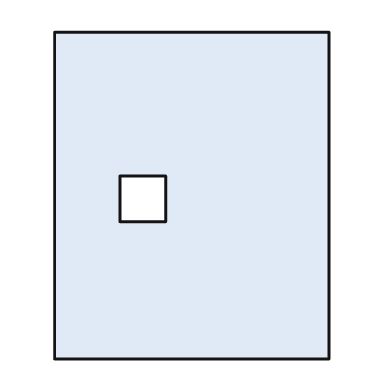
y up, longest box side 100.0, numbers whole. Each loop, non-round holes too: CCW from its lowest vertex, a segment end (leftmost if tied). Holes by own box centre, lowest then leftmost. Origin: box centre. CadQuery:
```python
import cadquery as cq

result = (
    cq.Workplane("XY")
    .moveTo(-42.0, -50.0)
    .lineTo(42.0, -50.0)
    .lineTo(42.0, 50.0)
    .lineTo(-42.0, 50.0)
    .close()
    .moveTo(-22.0, -8.0)
    .lineTo(-8.0, -8.0)
    .lineTo(-8.0, 6.0)
    .lineTo(-22.0, 6.0)
    .close()
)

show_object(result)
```